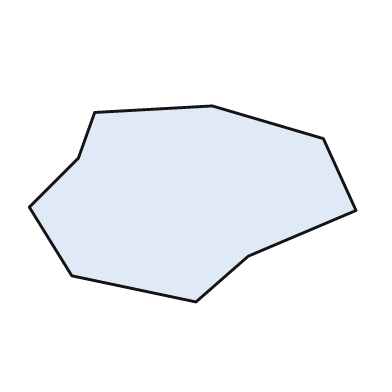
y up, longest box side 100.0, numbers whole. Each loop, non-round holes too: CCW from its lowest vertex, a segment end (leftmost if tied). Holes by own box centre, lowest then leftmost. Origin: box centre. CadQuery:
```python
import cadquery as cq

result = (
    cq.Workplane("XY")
    .moveTo(1.0, -30.0)
    .lineTo(17.0, -16.0)
    .lineTo(50.0, -2.0)
    .lineTo(40.0, 20.0)
    .lineTo(6.0, 30.0)
    .lineTo(-30.0, 28.0)
    .lineTo(-35.0, 14.0)
    .lineTo(-50.0, -1.0)
    .lineTo(-37.0, -22.0)
    .close()
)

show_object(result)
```